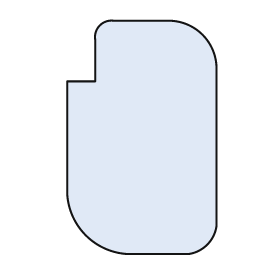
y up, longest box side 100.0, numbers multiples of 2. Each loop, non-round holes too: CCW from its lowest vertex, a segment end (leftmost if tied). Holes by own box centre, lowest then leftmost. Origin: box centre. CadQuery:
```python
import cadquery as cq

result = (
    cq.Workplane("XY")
    .moveTo(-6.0, -50.0)
    .lineTo(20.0, -50.0)
    .threePointArc((28.0, -46.0), (32.0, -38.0))
    .lineTo(32.0, 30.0)
    .threePointArc((26.0, 44.0), (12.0, 50.0))
    .lineTo(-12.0, 50.0)
    .threePointArc((-18.0, 48.0), (-20.0, 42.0))
    .lineTo(-20.0, 24.0)
    .lineTo(-32.0, 24.0)
    .lineTo(-32.0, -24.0)
    .threePointArc((-24.0, -42.0), (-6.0, -50.0))
    .close()
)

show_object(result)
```